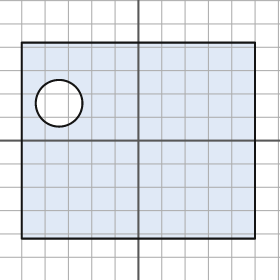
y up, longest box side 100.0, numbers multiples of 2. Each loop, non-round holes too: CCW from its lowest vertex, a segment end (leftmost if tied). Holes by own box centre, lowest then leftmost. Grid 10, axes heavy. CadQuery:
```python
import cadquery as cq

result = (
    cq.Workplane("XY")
    .moveTo(-50.0, -42.0)
    .lineTo(50.0, -42.0)
    .lineTo(50.0, 42.0)
    .lineTo(-50.0, 42.0)
    .close()
    .moveTo(-34.0, 16.0)
    .circle(10.0)
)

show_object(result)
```